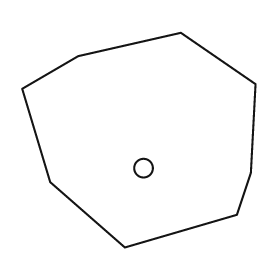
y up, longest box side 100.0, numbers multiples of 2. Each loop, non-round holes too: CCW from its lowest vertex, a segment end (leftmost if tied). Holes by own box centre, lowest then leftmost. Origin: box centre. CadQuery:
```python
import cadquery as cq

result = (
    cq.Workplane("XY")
    .moveTo(-6.0, -46.0)
    .lineTo(42.0, -32.0)
    .lineTo(48.0, -14.0)
    .lineTo(50.0, 24.0)
    .lineTo(18.0, 46.0)
    .lineTo(-26.0, 36.0)
    .lineTo(-50.0, 22.0)
    .lineTo(-38.0, -18.0)
    .close()
    .moveTo(2.0, -12.0)
    .circle(4.0)
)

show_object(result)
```